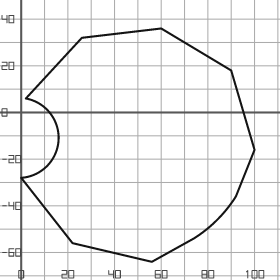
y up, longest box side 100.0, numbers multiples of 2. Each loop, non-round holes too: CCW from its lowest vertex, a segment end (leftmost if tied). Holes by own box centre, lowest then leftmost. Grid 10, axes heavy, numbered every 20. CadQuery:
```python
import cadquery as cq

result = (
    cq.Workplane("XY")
    .moveTo(56.0, -64.0)
    .lineTo(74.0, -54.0)
    .threePointArc((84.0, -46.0), (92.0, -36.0))
    .lineTo(100.0, -16.0)
    .lineTo(90.0, 18.0)
    .lineTo(60.0, 36.0)
    .lineTo(26.0, 32.0)
    .lineTo(2.0, 6.0)
    .threePointArc((16.0, -12.0), (0.0, -28.0))
    .lineTo(22.0, -56.0)
    .close()
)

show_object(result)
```